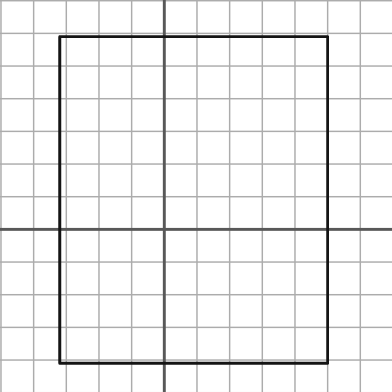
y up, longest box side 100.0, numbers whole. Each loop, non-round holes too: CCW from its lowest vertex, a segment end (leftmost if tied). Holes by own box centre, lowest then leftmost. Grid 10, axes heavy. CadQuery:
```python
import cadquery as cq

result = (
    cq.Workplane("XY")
    .moveTo(-32.0, -41.0)
    .lineTo(50.0, -41.0)
    .lineTo(50.0, 59.0)
    .lineTo(-32.0, 59.0)
    .close()
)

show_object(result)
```